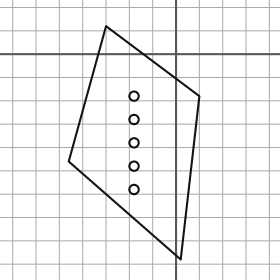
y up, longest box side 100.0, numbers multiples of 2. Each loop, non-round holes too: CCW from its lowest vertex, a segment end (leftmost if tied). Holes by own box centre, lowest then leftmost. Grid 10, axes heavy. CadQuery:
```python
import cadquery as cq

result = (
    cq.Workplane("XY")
    .moveTo(2.0, -88.0)
    .lineTo(10.0, -18.0)
    .lineTo(-30.0, 12.0)
    .lineTo(-46.0, -46.0)
    .close()
    .moveTo(-18.0, -58.0)
    .circle(2.0)
    .moveTo(-18.0, -48.0)
    .circle(2.0)
    .moveTo(-18.0, -38.0)
    .circle(2.0)
    .moveTo(-18.0, -28.0)
    .circle(2.0)
    .moveTo(-18.0, -18.0)
    .circle(2.0)
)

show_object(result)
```